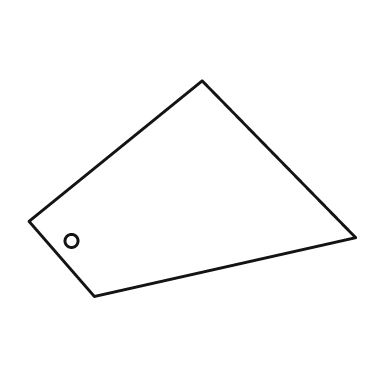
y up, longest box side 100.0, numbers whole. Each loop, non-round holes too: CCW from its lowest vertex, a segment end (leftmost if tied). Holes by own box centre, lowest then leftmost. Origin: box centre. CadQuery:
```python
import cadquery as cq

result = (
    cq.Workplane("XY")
    .moveTo(-30.0, -33.0)
    .lineTo(50.0, -15.0)
    .lineTo(3.0, 33.0)
    .lineTo(-50.0, -10.0)
    .close()
    .moveTo(-37.0, -16.0)
    .circle(2.0)
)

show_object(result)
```